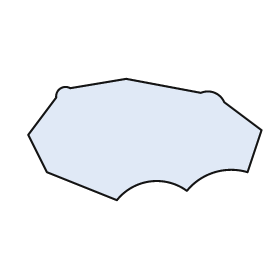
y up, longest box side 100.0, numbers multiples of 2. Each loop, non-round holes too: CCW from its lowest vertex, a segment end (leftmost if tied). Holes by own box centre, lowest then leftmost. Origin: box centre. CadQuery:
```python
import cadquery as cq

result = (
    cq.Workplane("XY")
    .moveTo(-12.0, -26.0)
    .threePointArc((2.0, -18.0), (18.0, -22.0))
    .threePointArc((30.0, -14.0), (44.0, -14.0))
    .lineTo(50.0, 4.0)
    .lineTo(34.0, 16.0)
    .threePointArc((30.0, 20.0), (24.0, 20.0))
    .lineTo(-8.0, 26.0)
    .lineTo(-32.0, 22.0)
    .threePointArc((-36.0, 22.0), (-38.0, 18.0))
    .lineTo(-50.0, 2.0)
    .lineTo(-42.0, -14.0)
    .close()
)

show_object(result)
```